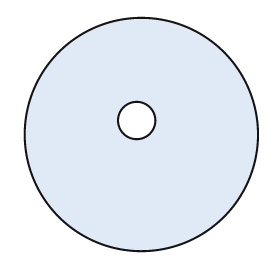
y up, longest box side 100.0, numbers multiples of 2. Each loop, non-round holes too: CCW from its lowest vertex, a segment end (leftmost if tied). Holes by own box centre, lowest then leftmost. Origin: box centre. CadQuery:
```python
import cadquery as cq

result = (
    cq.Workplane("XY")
    .moveTo(0.0, 0.0)
    .circle(50.0)
    .moveTo(-2.0, 6.0)
    .circle(8.0)
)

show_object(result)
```